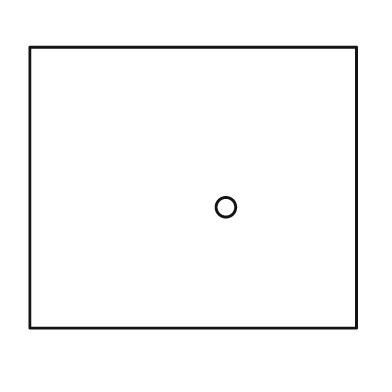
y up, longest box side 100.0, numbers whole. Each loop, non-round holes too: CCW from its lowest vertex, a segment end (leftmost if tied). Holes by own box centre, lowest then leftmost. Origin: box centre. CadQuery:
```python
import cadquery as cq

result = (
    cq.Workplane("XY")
    .moveTo(-50.0, -43.0)
    .lineTo(50.0, -43.0)
    .lineTo(50.0, 43.0)
    .lineTo(-50.0, 43.0)
    .close()
    .moveTo(10.0, -6.0)
    .circle(3.0)
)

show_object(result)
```